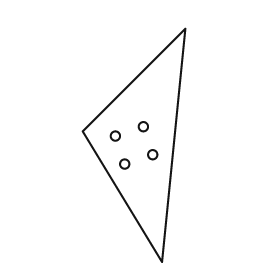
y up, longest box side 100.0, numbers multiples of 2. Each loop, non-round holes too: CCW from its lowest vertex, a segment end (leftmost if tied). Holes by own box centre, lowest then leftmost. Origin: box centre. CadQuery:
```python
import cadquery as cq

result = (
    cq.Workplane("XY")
    .moveTo(12.0, -50.0)
    .lineTo(22.0, 50.0)
    .lineTo(-22.0, 6.0)
    .close()
    .moveTo(-4.0, -8.0)
    .circle(2.0)
    .moveTo(8.0, -4.0)
    .circle(2.0)
    .moveTo(-8.0, 4.0)
    .circle(2.0)
    .moveTo(4.0, 8.0)
    .circle(2.0)
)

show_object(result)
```